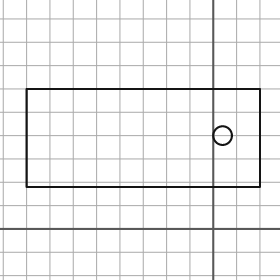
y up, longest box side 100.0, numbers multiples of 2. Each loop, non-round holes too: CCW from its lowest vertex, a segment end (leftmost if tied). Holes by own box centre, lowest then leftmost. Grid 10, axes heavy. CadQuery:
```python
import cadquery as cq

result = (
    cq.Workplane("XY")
    .moveTo(-80.0, 18.0)
    .lineTo(20.0, 18.0)
    .lineTo(20.0, 60.0)
    .lineTo(-80.0, 60.0)
    .close()
    .moveTo(4.0, 40.0)
    .circle(4.0)
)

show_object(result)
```